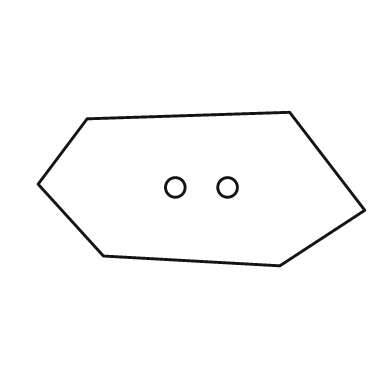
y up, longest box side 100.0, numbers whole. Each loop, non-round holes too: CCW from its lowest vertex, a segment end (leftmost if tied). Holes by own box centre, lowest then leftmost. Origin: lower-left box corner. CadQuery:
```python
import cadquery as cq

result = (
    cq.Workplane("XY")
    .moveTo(74.0, 0.0)
    .lineTo(100.0, 17.0)
    .lineTo(77.0, 47.0)
    .lineTo(15.0, 45.0)
    .lineTo(0.0, 25.0)
    .lineTo(20.0, 3.0)
    .close()
    .moveTo(42.0, 24.0)
    .circle(3.0)
    .moveTo(58.0, 24.0)
    .circle(3.0)
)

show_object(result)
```